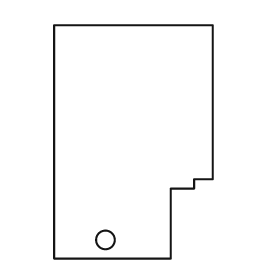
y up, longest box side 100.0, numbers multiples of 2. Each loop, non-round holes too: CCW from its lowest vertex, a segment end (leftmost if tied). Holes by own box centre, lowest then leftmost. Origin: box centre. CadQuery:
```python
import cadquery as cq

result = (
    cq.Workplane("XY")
    .moveTo(-34.0, -50.0)
    .lineTo(16.0, -50.0)
    .lineTo(16.0, -20.0)
    .lineTo(26.0, -20.0)
    .lineTo(26.0, -16.0)
    .lineTo(34.0, -16.0)
    .lineTo(34.0, 50.0)
    .lineTo(-34.0, 50.0)
    .close()
    .moveTo(-12.0, -42.0)
    .circle(4.0)
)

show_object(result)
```